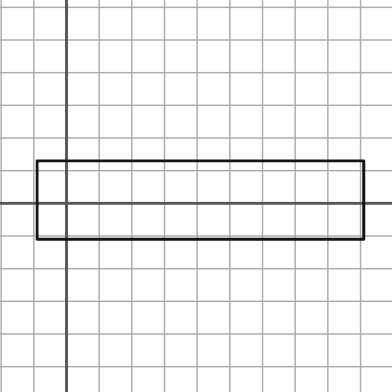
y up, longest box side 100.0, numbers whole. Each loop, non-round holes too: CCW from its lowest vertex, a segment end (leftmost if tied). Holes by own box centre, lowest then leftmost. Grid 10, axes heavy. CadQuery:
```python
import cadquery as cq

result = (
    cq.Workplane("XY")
    .moveTo(-9.0, -11.0)
    .lineTo(91.0, -11.0)
    .lineTo(91.0, 13.0)
    .lineTo(-9.0, 13.0)
    .close()
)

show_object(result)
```